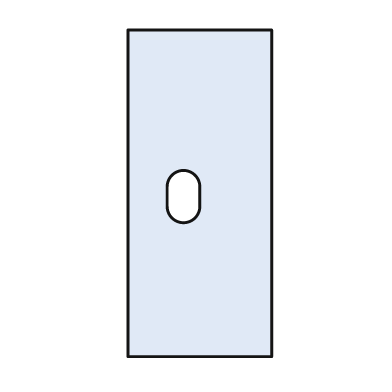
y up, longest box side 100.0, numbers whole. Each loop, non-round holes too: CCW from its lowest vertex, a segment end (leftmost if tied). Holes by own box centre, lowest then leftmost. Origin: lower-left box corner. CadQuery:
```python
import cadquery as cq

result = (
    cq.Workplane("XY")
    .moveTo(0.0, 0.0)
    .lineTo(44.0, 0.0)
    .lineTo(44.0, 100.0)
    .lineTo(0.0, 100.0)
    .close()
    .moveTo(12.0, 46.0)
    .threePointArc((17.0, 41.0), (22.0, 46.0))
    .lineTo(22.0, 52.0)
    .threePointArc((17.0, 57.0), (12.0, 52.0))
    .close()
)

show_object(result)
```